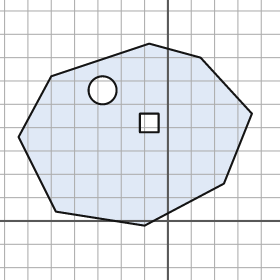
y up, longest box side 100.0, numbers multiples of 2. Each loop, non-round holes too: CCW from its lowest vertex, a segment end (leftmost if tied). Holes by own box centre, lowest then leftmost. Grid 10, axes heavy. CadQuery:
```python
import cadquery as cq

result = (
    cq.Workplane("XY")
    .moveTo(-10.0, -2.0)
    .lineTo(24.0, 16.0)
    .lineTo(36.0, 46.0)
    .lineTo(14.0, 70.0)
    .lineTo(-8.0, 76.0)
    .lineTo(-50.0, 62.0)
    .lineTo(-64.0, 36.0)
    .lineTo(-48.0, 4.0)
    .close()
    .moveTo(-12.0, 38.0)
    .lineTo(-4.0, 38.0)
    .lineTo(-4.0, 46.0)
    .lineTo(-12.0, 46.0)
    .close()
    .moveTo(-28.0, 56.0)
    .circle(6.0)
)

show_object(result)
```